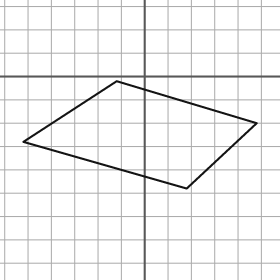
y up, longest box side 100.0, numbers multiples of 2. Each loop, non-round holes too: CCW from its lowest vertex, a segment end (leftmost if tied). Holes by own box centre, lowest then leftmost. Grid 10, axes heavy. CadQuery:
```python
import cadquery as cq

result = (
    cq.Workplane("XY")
    .moveTo(18.0, -48.0)
    .lineTo(48.0, -20.0)
    .lineTo(-12.0, -2.0)
    .lineTo(-52.0, -28.0)
    .close()
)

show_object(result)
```